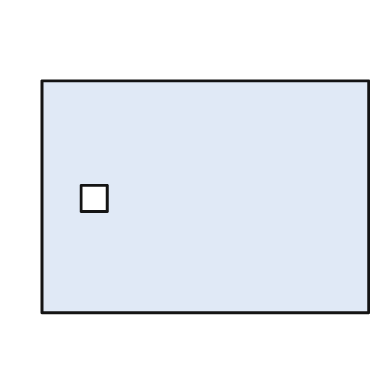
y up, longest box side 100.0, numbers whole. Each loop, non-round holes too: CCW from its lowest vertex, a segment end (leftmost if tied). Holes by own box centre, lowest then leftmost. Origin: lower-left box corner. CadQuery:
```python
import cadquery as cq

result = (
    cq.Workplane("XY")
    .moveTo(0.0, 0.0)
    .lineTo(100.0, 0.0)
    .lineTo(100.0, 71.0)
    .lineTo(0.0, 71.0)
    .close()
    .moveTo(12.0, 31.0)
    .lineTo(20.0, 31.0)
    .lineTo(20.0, 39.0)
    .lineTo(12.0, 39.0)
    .close()
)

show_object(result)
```